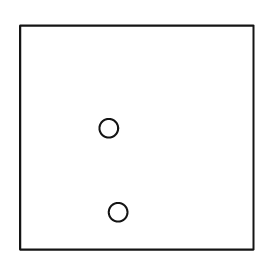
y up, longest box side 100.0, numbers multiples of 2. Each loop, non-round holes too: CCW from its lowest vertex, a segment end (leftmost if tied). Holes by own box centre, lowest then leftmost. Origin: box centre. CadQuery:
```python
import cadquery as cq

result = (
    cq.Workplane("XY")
    .moveTo(-50.0, -48.0)
    .lineTo(50.0, -48.0)
    .lineTo(50.0, 48.0)
    .lineTo(-50.0, 48.0)
    .close()
    .moveTo(-8.0, -32.0)
    .circle(4.0)
    .moveTo(-12.0, 4.0)
    .circle(4.0)
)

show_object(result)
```